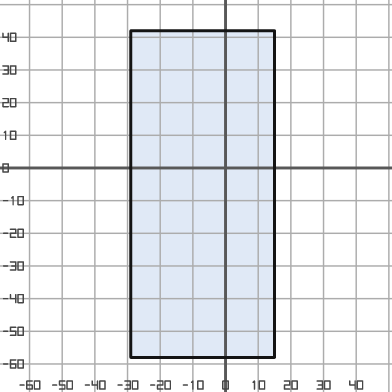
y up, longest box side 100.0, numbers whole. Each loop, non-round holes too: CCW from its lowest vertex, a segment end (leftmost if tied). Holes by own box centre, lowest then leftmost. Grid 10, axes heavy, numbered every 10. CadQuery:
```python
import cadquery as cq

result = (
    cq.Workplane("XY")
    .moveTo(-29.0, -58.0)
    .lineTo(15.0, -58.0)
    .lineTo(15.0, 42.0)
    .lineTo(-29.0, 42.0)
    .close()
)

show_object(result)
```